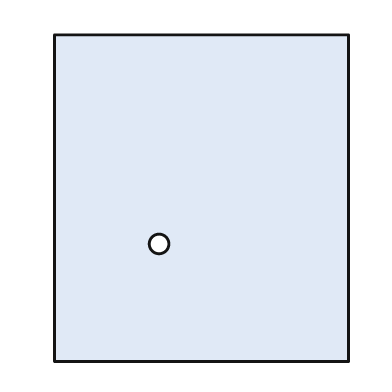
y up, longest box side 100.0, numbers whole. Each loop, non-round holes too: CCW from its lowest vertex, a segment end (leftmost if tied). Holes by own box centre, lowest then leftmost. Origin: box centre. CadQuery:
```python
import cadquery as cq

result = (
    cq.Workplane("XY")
    .moveTo(-45.0, -50.0)
    .lineTo(45.0, -50.0)
    .lineTo(45.0, 50.0)
    .lineTo(-45.0, 50.0)
    .close()
    .moveTo(-13.0, -14.0)
    .circle(3.0)
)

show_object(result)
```